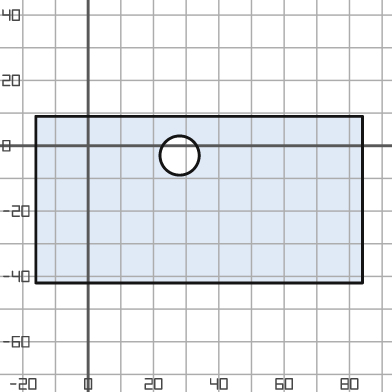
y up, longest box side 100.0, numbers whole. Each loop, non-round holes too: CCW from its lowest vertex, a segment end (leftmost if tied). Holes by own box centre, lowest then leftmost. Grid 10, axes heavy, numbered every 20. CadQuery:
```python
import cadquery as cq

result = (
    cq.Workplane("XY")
    .moveTo(-16.0, -42.0)
    .lineTo(84.0, -42.0)
    .lineTo(84.0, 9.0)
    .lineTo(-16.0, 9.0)
    .close()
    .moveTo(28.0, -3.0)
    .circle(6.0)
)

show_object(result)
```